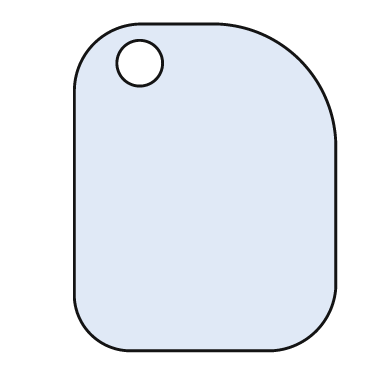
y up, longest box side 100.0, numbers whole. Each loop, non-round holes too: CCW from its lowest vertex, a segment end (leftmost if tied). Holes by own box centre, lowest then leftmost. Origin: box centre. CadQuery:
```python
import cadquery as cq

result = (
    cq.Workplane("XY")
    .moveTo(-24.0, -50.0)
    .lineTo(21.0, -50.0)
    .threePointArc((34.0, -44.0), (40.0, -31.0))
    .lineTo(40.0, 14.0)
    .threePointArc((29.0, 39.0), (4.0, 50.0))
    .lineTo(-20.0, 50.0)
    .threePointArc((-34.0, 44.0), (-40.0, 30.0))
    .lineTo(-40.0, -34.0)
    .threePointArc((-35.0, -45.0), (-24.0, -50.0))
    .close()
    .moveTo(-20.0, 38.0)
    .circle(7.0)
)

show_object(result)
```